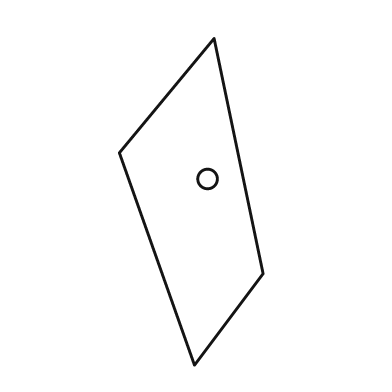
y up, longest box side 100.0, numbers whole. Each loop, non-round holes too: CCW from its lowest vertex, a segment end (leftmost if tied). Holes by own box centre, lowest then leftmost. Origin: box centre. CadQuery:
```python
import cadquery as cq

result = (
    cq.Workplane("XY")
    .moveTo(1.0, -50.0)
    .lineTo(22.0, -22.0)
    .lineTo(7.0, 50.0)
    .lineTo(-22.0, 15.0)
    .close()
    .moveTo(5.0, 7.0)
    .circle(3.0)
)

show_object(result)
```